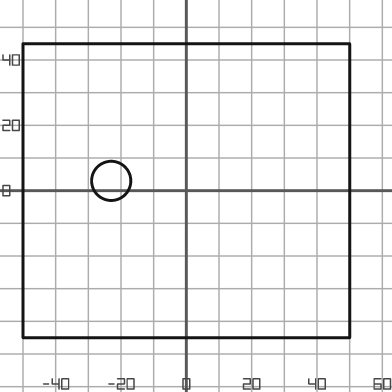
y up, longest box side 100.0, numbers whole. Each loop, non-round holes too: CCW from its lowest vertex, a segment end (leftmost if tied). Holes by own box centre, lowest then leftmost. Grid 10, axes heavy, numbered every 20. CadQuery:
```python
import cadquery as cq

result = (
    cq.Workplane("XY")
    .moveTo(-50.0, -45.0)
    .lineTo(50.0, -45.0)
    .lineTo(50.0, 45.0)
    .lineTo(-50.0, 45.0)
    .close()
    .moveTo(-23.0, 3.0)
    .circle(6.0)
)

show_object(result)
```